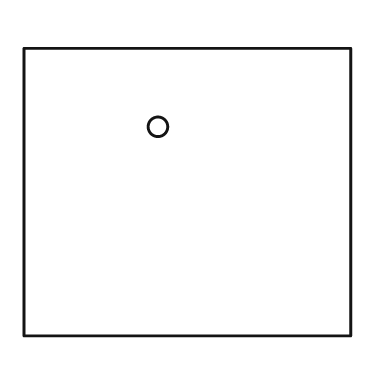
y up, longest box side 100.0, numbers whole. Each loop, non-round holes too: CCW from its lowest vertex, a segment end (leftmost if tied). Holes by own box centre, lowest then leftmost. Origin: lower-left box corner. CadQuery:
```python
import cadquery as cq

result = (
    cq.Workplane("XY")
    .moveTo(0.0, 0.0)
    .lineTo(100.0, 0.0)
    .lineTo(100.0, 88.0)
    .lineTo(0.0, 88.0)
    .close()
    .moveTo(41.0, 64.0)
    .circle(3.0)
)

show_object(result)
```